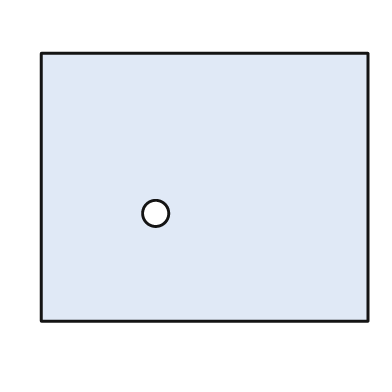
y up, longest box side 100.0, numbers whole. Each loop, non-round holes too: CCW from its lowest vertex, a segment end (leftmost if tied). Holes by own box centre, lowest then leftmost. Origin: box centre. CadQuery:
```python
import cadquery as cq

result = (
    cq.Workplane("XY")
    .moveTo(-50.0, -41.0)
    .lineTo(50.0, -41.0)
    .lineTo(50.0, 41.0)
    .lineTo(-50.0, 41.0)
    .close()
    .moveTo(-15.0, -8.0)
    .circle(4.0)
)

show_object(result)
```